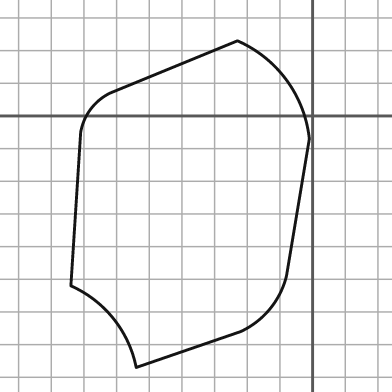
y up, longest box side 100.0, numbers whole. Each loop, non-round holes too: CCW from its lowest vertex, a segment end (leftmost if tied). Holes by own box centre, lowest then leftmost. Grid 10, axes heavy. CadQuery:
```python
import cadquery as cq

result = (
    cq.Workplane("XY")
    .moveTo(-54.0, -77.0)
    .lineTo(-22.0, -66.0)
    .threePointArc((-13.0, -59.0), (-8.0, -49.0))
    .lineTo(-1.0, -7.0)
    .threePointArc((-8.0, 11.0), (-23.0, 23.0))
    .lineTo(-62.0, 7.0)
    .threePointArc((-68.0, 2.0), (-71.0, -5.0))
    .lineTo(-74.0, -52.0)
    .threePointArc((-61.0, -62.0), (-54.0, -77.0))
    .close()
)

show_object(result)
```